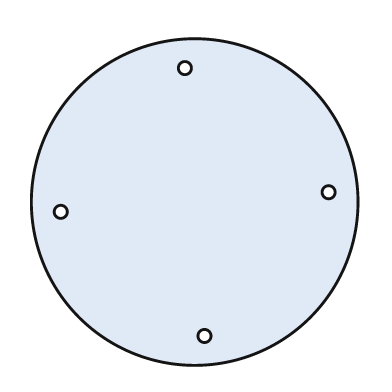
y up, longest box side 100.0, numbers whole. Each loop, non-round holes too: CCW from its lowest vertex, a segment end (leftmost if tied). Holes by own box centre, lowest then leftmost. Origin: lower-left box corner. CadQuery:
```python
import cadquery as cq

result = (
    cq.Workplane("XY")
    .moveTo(50.0, 50.0)
    .circle(50.0)
    .moveTo(53.0, 9.0)
    .circle(2.0)
    .moveTo(9.0, 47.0)
    .circle(2.0)
    .moveTo(91.0, 53.0)
    .circle(2.0)
    .moveTo(47.0, 91.0)
    .circle(2.0)
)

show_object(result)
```